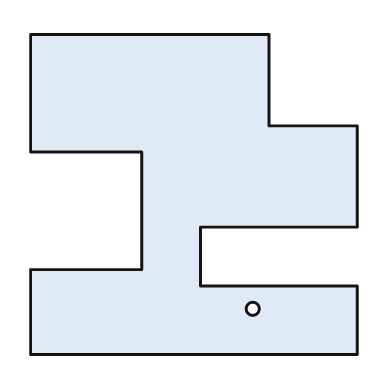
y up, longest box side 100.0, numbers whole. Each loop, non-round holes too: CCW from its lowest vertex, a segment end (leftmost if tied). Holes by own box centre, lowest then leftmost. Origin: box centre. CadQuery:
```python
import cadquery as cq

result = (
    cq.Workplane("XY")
    .moveTo(-50.0, -49.0)
    .lineTo(50.0, -49.0)
    .lineTo(50.0, -28.0)
    .lineTo(2.0, -28.0)
    .lineTo(2.0, -10.0)
    .lineTo(50.0, -10.0)
    .lineTo(50.0, 21.0)
    .lineTo(23.0, 21.0)
    .lineTo(23.0, 49.0)
    .lineTo(-50.0, 49.0)
    .lineTo(-50.0, 13.0)
    .lineTo(-16.0, 13.0)
    .lineTo(-16.0, -23.0)
    .lineTo(-50.0, -23.0)
    .close()
    .moveTo(18.0, -35.0)
    .circle(2.0)
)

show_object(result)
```